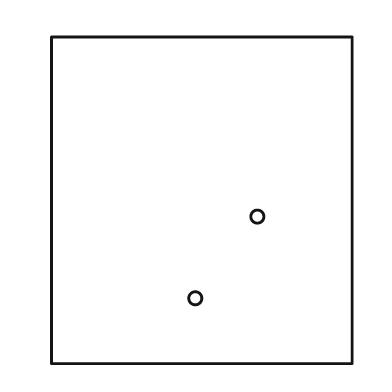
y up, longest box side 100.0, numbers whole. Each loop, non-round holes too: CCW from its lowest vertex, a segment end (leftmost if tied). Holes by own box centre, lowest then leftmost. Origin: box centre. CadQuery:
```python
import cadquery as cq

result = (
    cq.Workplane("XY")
    .moveTo(-46.0, -50.0)
    .lineTo(46.0, -50.0)
    .lineTo(46.0, 50.0)
    .lineTo(-46.0, 50.0)
    .close()
    .moveTo(-2.0, -30.0)
    .circle(2.0)
    .moveTo(17.0, -5.0)
    .circle(2.0)
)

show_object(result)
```